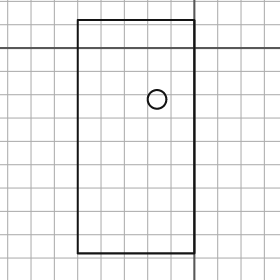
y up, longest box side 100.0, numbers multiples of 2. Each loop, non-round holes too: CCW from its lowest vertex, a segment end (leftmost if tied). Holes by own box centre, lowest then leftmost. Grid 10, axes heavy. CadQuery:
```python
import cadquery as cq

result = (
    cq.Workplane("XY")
    .moveTo(-50.0, -88.0)
    .lineTo(0.0, -88.0)
    .lineTo(0.0, 12.0)
    .lineTo(-50.0, 12.0)
    .close()
    .moveTo(-16.0, -22.0)
    .circle(4.0)
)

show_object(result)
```